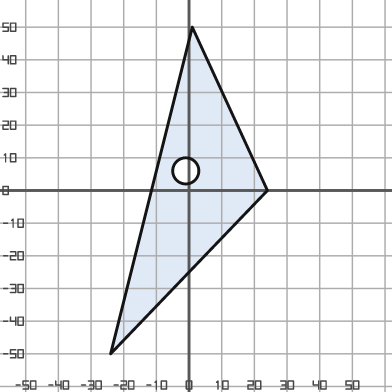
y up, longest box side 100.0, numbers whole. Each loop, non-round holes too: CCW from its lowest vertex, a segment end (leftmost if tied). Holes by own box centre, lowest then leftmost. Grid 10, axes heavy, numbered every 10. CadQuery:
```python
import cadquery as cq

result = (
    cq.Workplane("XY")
    .moveTo(-24.0, -50.0)
    .lineTo(24.0, 0.0)
    .lineTo(1.0, 50.0)
    .close()
    .moveTo(-1.0, 6.0)
    .circle(4.0)
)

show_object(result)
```